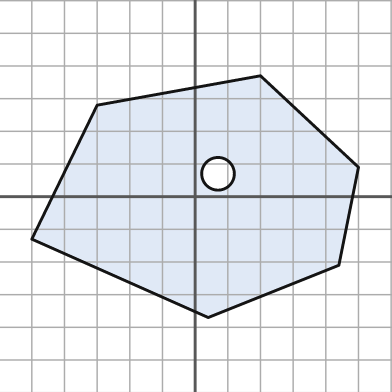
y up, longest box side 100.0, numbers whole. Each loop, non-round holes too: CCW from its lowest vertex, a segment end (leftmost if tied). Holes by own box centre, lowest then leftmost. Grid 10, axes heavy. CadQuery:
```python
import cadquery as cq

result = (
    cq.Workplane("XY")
    .moveTo(4.0, -37.0)
    .lineTo(44.0, -21.0)
    .lineTo(50.0, 9.0)
    .lineTo(20.0, 37.0)
    .lineTo(-30.0, 28.0)
    .lineTo(-50.0, -13.0)
    .close()
    .moveTo(7.0, 7.0)
    .circle(5.0)
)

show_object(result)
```